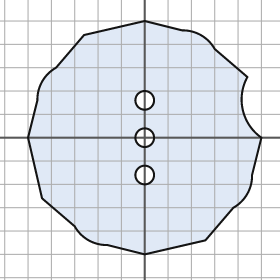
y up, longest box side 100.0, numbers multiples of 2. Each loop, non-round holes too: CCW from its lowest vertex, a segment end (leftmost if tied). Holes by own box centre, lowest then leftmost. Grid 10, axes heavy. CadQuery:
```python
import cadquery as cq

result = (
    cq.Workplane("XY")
    .moveTo(0.0, -50.0)
    .lineTo(26.0, -44.0)
    .lineTo(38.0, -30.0)
    .threePointArc((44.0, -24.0), (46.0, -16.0))
    .lineTo(50.0, 0.0)
    .threePointArc((42.0, 12.0), (44.0, 26.0))
    .lineTo(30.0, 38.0)
    .threePointArc((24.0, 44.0), (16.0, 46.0))
    .lineTo(0.0, 50.0)
    .lineTo(-26.0, 44.0)
    .lineTo(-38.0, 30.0)
    .threePointArc((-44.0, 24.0), (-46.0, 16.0))
    .lineTo(-50.0, 0.0)
    .lineTo(-44.0, -26.0)
    .lineTo(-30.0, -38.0)
    .threePointArc((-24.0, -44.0), (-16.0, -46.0))
    .close()
    .moveTo(0.0, -16.0)
    .circle(4.0)
    .moveTo(0.0, 0.0)
    .circle(4.0)
    .moveTo(0.0, 16.0)
    .circle(4.0)
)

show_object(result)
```